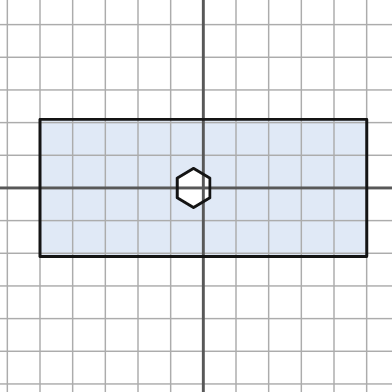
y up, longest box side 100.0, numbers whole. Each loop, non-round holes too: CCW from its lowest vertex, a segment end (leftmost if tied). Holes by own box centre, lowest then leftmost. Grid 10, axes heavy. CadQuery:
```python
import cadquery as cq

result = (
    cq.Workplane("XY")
    .moveTo(-50.0, -21.0)
    .lineTo(50.0, -21.0)
    .lineTo(50.0, 21.0)
    .lineTo(-50.0, 21.0)
    .close()
    .moveTo(-3.0, -6.0)
    .lineTo(2.0, -3.0)
    .lineTo(2.0, 3.0)
    .lineTo(-3.0, 6.0)
    .lineTo(-8.0, 3.0)
    .lineTo(-8.0, -3.0)
    .close()
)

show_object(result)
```